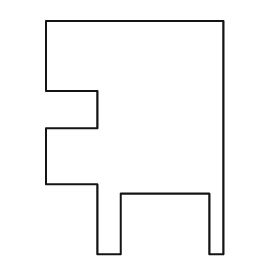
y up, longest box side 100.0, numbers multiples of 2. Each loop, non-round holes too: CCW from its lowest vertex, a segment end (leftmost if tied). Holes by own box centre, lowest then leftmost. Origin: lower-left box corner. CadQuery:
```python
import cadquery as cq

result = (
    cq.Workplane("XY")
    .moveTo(22.0, 0.0)
    .lineTo(32.0, 0.0)
    .lineTo(32.0, 26.0)
    .lineTo(70.0, 26.0)
    .lineTo(70.0, 0.0)
    .lineTo(76.0, 0.0)
    .lineTo(76.0, 100.0)
    .lineTo(0.0, 100.0)
    .lineTo(0.0, 70.0)
    .lineTo(22.0, 70.0)
    .lineTo(22.0, 54.0)
    .lineTo(0.0, 54.0)
    .lineTo(0.0, 30.0)
    .lineTo(22.0, 30.0)
    .close()
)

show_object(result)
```